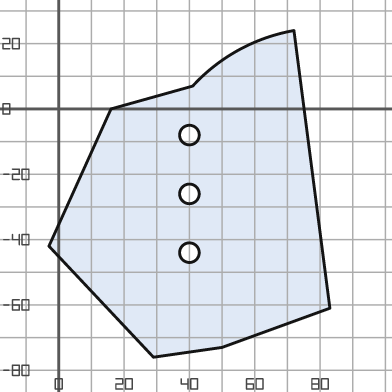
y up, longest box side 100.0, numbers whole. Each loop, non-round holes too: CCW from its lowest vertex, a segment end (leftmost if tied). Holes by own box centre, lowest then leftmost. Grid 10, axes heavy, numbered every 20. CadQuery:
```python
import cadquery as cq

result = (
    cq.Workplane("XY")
    .moveTo(29.0, -76.0)
    .lineTo(50.0, -73.0)
    .lineTo(83.0, -61.0)
    .lineTo(72.0, 24.0)
    .threePointArc((55.0, 18.0), (41.0, 7.0))
    .lineTo(16.0, 0.0)
    .lineTo(-3.0, -42.0)
    .close()
    .moveTo(40.0, -44.0)
    .circle(3.0)
    .moveTo(40.0, -26.0)
    .circle(3.0)
    .moveTo(40.0, -8.0)
    .circle(3.0)
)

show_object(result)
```